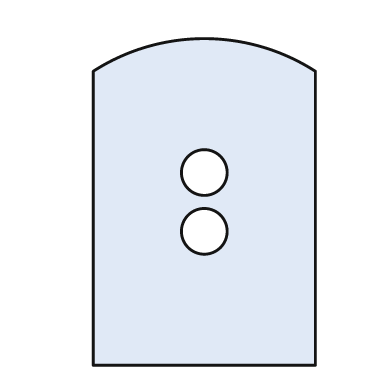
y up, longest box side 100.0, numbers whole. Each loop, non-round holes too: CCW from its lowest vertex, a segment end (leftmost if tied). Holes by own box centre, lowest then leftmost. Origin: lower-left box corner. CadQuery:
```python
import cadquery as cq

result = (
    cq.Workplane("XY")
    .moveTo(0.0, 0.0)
    .lineTo(68.0, 0.0)
    .lineTo(68.0, 90.0)
    .threePointArc((34.0, 100.0), (0.0, 90.0))
    .close()
    .moveTo(34.0, 41.0)
    .circle(7.0)
    .moveTo(34.0, 59.0)
    .circle(7.0)
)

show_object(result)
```